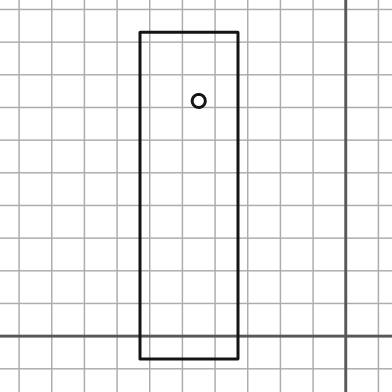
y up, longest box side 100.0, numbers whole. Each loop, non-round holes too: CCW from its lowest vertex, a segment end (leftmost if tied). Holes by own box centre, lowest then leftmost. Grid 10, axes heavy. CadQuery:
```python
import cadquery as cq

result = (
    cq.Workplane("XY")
    .moveTo(-63.0, -7.0)
    .lineTo(-33.0, -7.0)
    .lineTo(-33.0, 93.0)
    .lineTo(-63.0, 93.0)
    .close()
    .moveTo(-45.0, 72.0)
    .circle(2.0)
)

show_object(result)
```